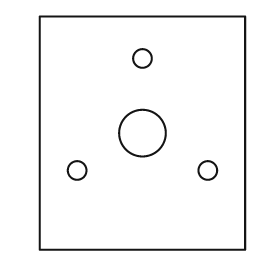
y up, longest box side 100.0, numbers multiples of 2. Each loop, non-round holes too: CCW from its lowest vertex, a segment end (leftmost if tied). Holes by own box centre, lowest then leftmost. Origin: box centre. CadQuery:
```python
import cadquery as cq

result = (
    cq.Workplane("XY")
    .moveTo(-44.0, -50.0)
    .lineTo(44.0, -50.0)
    .lineTo(44.0, 50.0)
    .lineTo(-44.0, 50.0)
    .close()
    .moveTo(-28.0, -16.0)
    .circle(4.0)
    .moveTo(28.0, -16.0)
    .circle(4.0)
    .moveTo(0.0, 0.0)
    .circle(10.0)
    .moveTo(0.0, 32.0)
    .circle(4.0)
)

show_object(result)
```